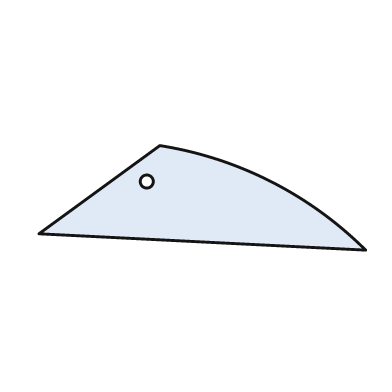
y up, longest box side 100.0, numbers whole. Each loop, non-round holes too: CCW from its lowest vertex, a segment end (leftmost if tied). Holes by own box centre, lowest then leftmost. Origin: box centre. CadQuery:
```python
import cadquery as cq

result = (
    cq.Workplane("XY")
    .moveTo(50.0, -16.0)
    .threePointArc((21.0, 5.0), (-13.0, 16.0))
    .lineTo(-50.0, -11.0)
    .close()
    .moveTo(-17.0, 5.0)
    .circle(2.0)
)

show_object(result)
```